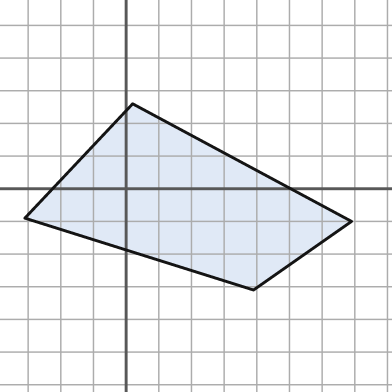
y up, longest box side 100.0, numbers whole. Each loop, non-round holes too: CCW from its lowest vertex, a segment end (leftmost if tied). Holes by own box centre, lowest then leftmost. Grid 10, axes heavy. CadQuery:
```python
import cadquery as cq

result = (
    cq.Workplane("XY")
    .moveTo(39.0, -31.0)
    .lineTo(69.0, -10.0)
    .lineTo(2.0, 26.0)
    .lineTo(-31.0, -9.0)
    .close()
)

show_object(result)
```